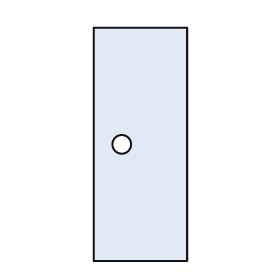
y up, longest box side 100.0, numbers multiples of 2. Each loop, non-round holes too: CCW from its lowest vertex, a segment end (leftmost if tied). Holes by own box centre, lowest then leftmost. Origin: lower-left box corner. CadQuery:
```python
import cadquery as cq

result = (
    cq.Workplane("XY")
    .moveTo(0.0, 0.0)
    .lineTo(40.0, 0.0)
    .lineTo(40.0, 100.0)
    .lineTo(0.0, 100.0)
    .close()
    .moveTo(12.0, 50.0)
    .circle(4.0)
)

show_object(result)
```